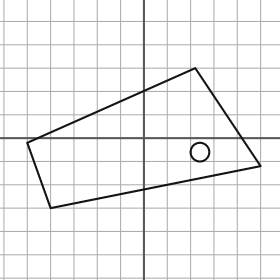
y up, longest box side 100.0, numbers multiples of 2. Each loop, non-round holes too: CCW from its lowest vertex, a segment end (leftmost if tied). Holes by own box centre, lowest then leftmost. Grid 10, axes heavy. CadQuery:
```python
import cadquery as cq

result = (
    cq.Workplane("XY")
    .moveTo(-40.0, -30.0)
    .lineTo(50.0, -12.0)
    .lineTo(22.0, 30.0)
    .lineTo(-50.0, -2.0)
    .close()
    .moveTo(24.0, -6.0)
    .circle(4.0)
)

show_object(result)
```